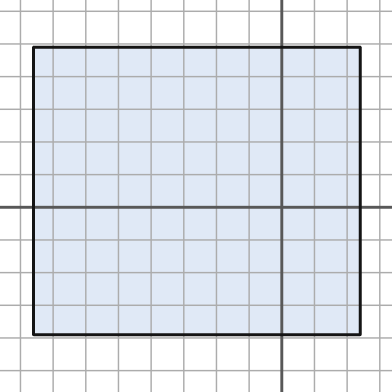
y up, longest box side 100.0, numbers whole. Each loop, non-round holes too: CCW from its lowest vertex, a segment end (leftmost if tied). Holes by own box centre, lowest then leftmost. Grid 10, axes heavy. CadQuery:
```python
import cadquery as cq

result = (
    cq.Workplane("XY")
    .moveTo(-76.0, -39.0)
    .lineTo(24.0, -39.0)
    .lineTo(24.0, 49.0)
    .lineTo(-76.0, 49.0)
    .close()
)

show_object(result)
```